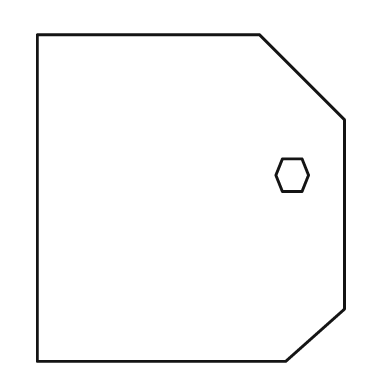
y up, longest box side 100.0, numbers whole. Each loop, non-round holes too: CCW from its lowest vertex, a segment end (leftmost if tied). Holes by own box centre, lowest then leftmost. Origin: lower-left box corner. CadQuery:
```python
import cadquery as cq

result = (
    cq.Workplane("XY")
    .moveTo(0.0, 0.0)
    .lineTo(76.0, 0.0)
    .lineTo(94.0, 16.0)
    .lineTo(94.0, 74.0)
    .lineTo(68.0, 100.0)
    .lineTo(0.0, 100.0)
    .close()
    .moveTo(75.0, 52.0)
    .lineTo(81.0, 52.0)
    .lineTo(83.0, 57.0)
    .lineTo(81.0, 62.0)
    .lineTo(75.0, 62.0)
    .lineTo(73.0, 57.0)
    .close()
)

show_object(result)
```